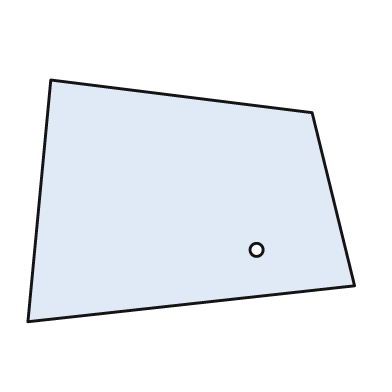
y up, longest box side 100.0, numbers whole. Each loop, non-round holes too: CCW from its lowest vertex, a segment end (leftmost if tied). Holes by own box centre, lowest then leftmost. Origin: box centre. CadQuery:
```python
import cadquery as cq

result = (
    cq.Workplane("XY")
    .moveTo(-50.0, -37.0)
    .lineTo(50.0, -26.0)
    .lineTo(37.0, 27.0)
    .lineTo(-43.0, 37.0)
    .close()
    .moveTo(20.0, -15.0)
    .circle(2.0)
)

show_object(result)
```